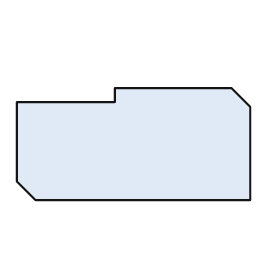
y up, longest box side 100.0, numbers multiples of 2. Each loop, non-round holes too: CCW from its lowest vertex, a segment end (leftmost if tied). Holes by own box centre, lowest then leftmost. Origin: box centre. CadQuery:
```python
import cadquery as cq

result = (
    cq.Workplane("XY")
    .moveTo(-42.0, -24.0)
    .lineTo(50.0, -24.0)
    .lineTo(50.0, 16.0)
    .lineTo(42.0, 24.0)
    .lineTo(-8.0, 24.0)
    .lineTo(-8.0, 18.0)
    .lineTo(-50.0, 18.0)
    .lineTo(-50.0, -16.0)
    .close()
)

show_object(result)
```